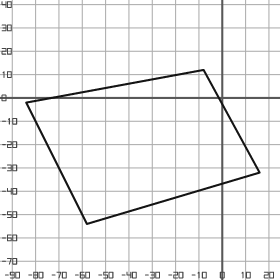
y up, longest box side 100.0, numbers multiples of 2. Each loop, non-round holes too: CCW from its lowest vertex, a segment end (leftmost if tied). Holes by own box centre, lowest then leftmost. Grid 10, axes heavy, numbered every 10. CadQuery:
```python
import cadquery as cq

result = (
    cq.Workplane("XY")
    .moveTo(-58.0, -54.0)
    .lineTo(16.0, -32.0)
    .lineTo(-8.0, 12.0)
    .lineTo(-84.0, -2.0)
    .close()
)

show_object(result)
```